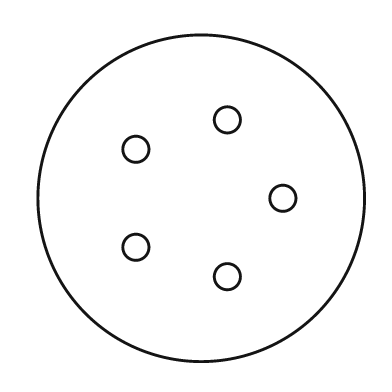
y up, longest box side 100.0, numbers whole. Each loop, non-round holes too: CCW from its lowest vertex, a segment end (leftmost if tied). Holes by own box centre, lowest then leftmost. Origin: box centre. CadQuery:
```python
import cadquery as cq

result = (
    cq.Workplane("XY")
    .moveTo(0.0, 0.0)
    .circle(50.0)
    .moveTo(8.0, -24.0)
    .circle(4.0)
    .moveTo(-20.0, -15.0)
    .circle(4.0)
    .moveTo(25.0, 0.0)
    .circle(4.0)
    .moveTo(-20.0, 15.0)
    .circle(4.0)
    .moveTo(8.0, 24.0)
    .circle(4.0)
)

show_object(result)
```